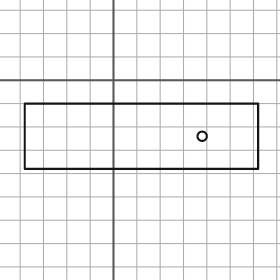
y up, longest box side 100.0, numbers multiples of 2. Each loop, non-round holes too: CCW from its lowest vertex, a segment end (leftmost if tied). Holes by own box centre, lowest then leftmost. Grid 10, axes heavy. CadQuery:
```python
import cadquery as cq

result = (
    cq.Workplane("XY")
    .moveTo(-38.0, -38.0)
    .lineTo(62.0, -38.0)
    .lineTo(62.0, -10.0)
    .lineTo(-38.0, -10.0)
    .close()
    .moveTo(38.0, -24.0)
    .circle(2.0)
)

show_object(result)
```